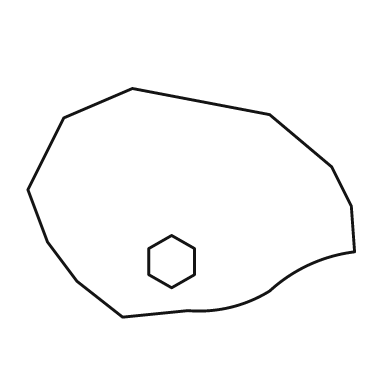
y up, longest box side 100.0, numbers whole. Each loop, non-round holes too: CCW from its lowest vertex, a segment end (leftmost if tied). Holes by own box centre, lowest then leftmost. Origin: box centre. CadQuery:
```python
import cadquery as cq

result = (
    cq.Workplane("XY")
    .moveTo(-21.0, -35.0)
    .lineTo(-1.0, -33.0)
    .threePointArc((12.0, -32.0), (24.0, -27.0))
    .threePointArc((36.0, -19.0), (50.0, -15.0))
    .lineTo(49.0, -1.0)
    .lineTo(43.0, 11.0)
    .lineTo(24.0, 27.0)
    .lineTo(-18.0, 35.0)
    .lineTo(-39.0, 26.0)
    .lineTo(-50.0, 4.0)
    .lineTo(-44.0, -12.0)
    .lineTo(-35.0, -24.0)
    .close()
    .moveTo(-6.0, -26.0)
    .lineTo(1.0, -22.0)
    .lineTo(1.0, -14.0)
    .lineTo(-6.0, -10.0)
    .lineTo(-13.0, -14.0)
    .lineTo(-13.0, -22.0)
    .close()
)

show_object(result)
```